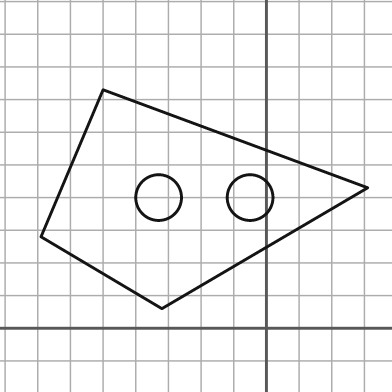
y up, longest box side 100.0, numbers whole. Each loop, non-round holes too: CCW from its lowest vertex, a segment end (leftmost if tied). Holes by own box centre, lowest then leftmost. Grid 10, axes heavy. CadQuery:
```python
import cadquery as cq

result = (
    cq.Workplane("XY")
    .moveTo(-32.0, 6.0)
    .lineTo(31.0, 43.0)
    .lineTo(-50.0, 73.0)
    .lineTo(-69.0, 28.0)
    .close()
    .moveTo(-33.0, 40.0)
    .circle(7.0)
    .moveTo(-5.0, 40.0)
    .circle(7.0)
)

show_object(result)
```